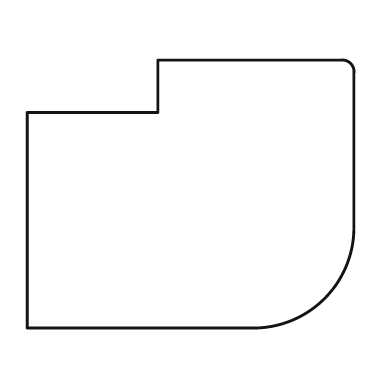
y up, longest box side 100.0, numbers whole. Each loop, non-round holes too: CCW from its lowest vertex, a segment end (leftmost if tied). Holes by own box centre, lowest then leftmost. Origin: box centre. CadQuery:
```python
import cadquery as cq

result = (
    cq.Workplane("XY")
    .moveTo(-50.0, -41.0)
    .lineTo(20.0, -41.0)
    .threePointArc((41.0, -32.0), (50.0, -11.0))
    .lineTo(50.0, 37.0)
    .threePointArc((49.0, 40.0), (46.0, 41.0))
    .lineTo(-10.0, 41.0)
    .lineTo(-10.0, 25.0)
    .lineTo(-50.0, 25.0)
    .close()
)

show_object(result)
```